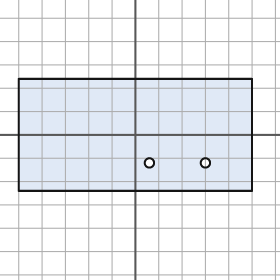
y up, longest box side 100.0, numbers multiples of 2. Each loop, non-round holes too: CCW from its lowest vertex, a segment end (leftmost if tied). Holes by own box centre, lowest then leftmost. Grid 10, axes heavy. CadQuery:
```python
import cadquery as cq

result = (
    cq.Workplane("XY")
    .moveTo(-50.0, -24.0)
    .lineTo(50.0, -24.0)
    .lineTo(50.0, 24.0)
    .lineTo(-50.0, 24.0)
    .close()
    .moveTo(6.0, -12.0)
    .circle(2.0)
    .moveTo(30.0, -12.0)
    .circle(2.0)
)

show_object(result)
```